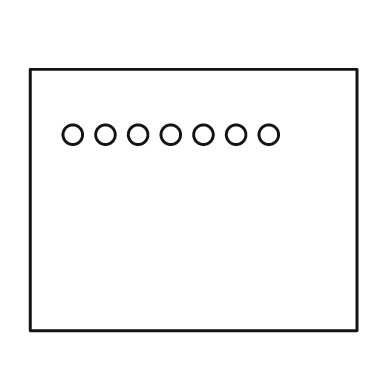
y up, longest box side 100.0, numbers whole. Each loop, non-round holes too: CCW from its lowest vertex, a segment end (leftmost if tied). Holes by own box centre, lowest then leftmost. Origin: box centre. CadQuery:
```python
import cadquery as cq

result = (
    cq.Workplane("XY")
    .moveTo(-50.0, -40.0)
    .lineTo(50.0, -40.0)
    .lineTo(50.0, 40.0)
    .lineTo(-50.0, 40.0)
    .close()
    .moveTo(-37.0, 20.0)
    .circle(3.0)
    .moveTo(-27.0, 20.0)
    .circle(3.0)
    .moveTo(-17.0, 20.0)
    .circle(3.0)
    .moveTo(-7.0, 20.0)
    .circle(3.0)
    .moveTo(3.0, 20.0)
    .circle(3.0)
    .moveTo(13.0, 20.0)
    .circle(3.0)
    .moveTo(23.0, 20.0)
    .circle(3.0)
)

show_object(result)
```